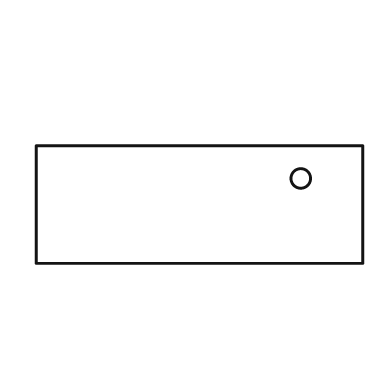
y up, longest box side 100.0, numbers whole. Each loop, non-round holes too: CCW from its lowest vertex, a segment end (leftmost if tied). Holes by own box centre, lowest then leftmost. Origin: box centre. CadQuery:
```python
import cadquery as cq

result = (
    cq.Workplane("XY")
    .moveTo(-50.0, -18.0)
    .lineTo(50.0, -18.0)
    .lineTo(50.0, 18.0)
    .lineTo(-50.0, 18.0)
    .close()
    .moveTo(31.0, 8.0)
    .circle(3.0)
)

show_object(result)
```